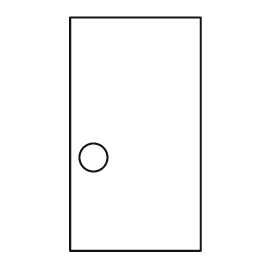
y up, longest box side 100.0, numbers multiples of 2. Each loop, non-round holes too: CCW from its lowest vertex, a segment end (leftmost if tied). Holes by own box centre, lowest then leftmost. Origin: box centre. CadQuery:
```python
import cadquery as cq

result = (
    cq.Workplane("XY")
    .moveTo(-28.0, -50.0)
    .lineTo(28.0, -50.0)
    .lineTo(28.0, 50.0)
    .lineTo(-28.0, 50.0)
    .close()
    .moveTo(-18.0, -10.0)
    .circle(6.0)
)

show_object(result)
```